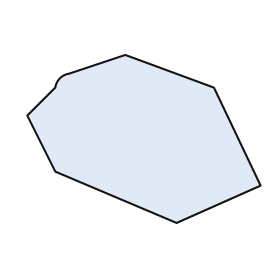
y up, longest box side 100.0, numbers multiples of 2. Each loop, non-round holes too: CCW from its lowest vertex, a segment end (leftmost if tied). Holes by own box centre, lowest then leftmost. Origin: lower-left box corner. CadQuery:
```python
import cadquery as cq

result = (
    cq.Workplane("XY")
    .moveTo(64.0, 0.0)
    .lineTo(100.0, 16.0)
    .lineTo(80.0, 58.0)
    .lineTo(42.0, 72.0)
    .lineTo(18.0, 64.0)
    .threePointArc((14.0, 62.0), (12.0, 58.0))
    .lineTo(0.0, 46.0)
    .lineTo(12.0, 22.0)
    .close()
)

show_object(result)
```